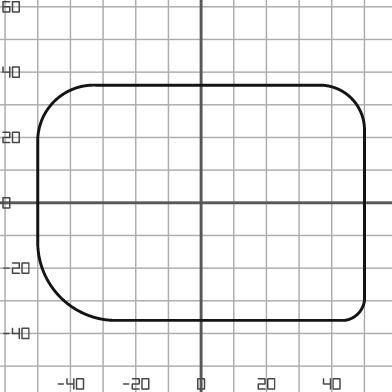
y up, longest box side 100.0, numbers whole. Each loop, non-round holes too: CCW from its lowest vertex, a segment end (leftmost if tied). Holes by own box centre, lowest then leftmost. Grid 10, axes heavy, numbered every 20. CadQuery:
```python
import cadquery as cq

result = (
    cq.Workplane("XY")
    .moveTo(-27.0, -36.0)
    .lineTo(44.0, -36.0)
    .threePointArc((48.0, -34.0), (50.0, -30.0))
    .lineTo(50.0, 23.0)
    .threePointArc((46.0, 32.0), (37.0, 36.0))
    .lineTo(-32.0, 36.0)
    .threePointArc((-45.0, 31.0), (-50.0, 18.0))
    .lineTo(-50.0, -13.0)
    .threePointArc((-43.0, -29.0), (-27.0, -36.0))
    .close()
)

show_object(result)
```